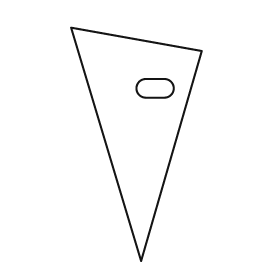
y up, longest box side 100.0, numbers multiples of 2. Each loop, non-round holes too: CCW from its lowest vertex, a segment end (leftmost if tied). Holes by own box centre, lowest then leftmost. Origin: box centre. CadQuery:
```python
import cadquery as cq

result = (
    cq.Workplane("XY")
    .moveTo(2.0, -50.0)
    .lineTo(28.0, 40.0)
    .lineTo(-28.0, 50.0)
    .close()
    .moveTo(4.0, 20.0)
    .lineTo(12.0, 20.0)
    .threePointArc((16.0, 24.0), (12.0, 28.0))
    .lineTo(4.0, 28.0)
    .threePointArc((0.0, 24.0), (4.0, 20.0))
    .close()
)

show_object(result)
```